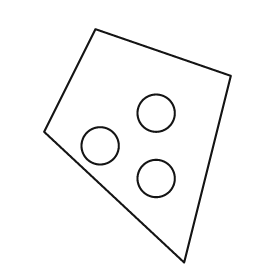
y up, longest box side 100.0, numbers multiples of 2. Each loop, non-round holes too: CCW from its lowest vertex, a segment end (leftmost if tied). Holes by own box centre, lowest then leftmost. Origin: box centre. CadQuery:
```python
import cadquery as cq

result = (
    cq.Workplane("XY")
    .moveTo(20.0, -50.0)
    .lineTo(40.0, 30.0)
    .lineTo(-18.0, 50.0)
    .lineTo(-40.0, 6.0)
    .close()
    .moveTo(8.0, -14.0)
    .circle(8.0)
    .moveTo(-16.0, 0.0)
    .circle(8.0)
    .moveTo(8.0, 14.0)
    .circle(8.0)
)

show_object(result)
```